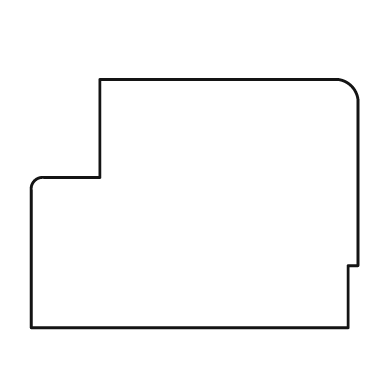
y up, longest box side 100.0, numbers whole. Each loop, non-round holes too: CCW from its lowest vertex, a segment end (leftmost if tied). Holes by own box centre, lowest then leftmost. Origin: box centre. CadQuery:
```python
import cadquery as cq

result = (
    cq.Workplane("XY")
    .moveTo(-50.0, -38.0)
    .lineTo(47.0, -38.0)
    .lineTo(47.0, -19.0)
    .lineTo(50.0, -19.0)
    .lineTo(50.0, 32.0)
    .threePointArc((48.0, 36.0), (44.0, 38.0))
    .lineTo(-29.0, 38.0)
    .lineTo(-29.0, 8.0)
    .lineTo(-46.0, 8.0)
    .threePointArc((-49.0, 7.0), (-50.0, 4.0))
    .close()
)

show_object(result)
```